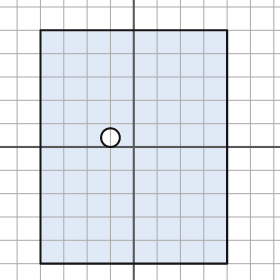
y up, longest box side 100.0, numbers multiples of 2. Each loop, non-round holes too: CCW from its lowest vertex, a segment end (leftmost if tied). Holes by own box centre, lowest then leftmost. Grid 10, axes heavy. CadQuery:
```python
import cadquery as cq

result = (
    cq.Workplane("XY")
    .moveTo(-40.0, -50.0)
    .lineTo(40.0, -50.0)
    .lineTo(40.0, 50.0)
    .lineTo(-40.0, 50.0)
    .close()
    .moveTo(-10.0, 4.0)
    .circle(4.0)
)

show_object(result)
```